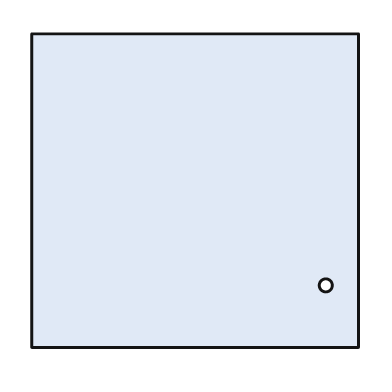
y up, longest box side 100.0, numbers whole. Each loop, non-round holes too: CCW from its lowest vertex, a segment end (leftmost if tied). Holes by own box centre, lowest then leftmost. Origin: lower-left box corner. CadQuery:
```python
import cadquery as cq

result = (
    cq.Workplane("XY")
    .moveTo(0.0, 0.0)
    .lineTo(100.0, 0.0)
    .lineTo(100.0, 96.0)
    .lineTo(0.0, 96.0)
    .close()
    .moveTo(90.0, 19.0)
    .circle(2.0)
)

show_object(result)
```